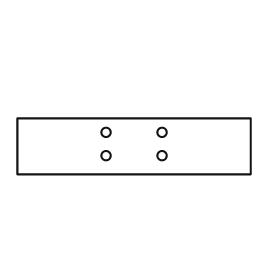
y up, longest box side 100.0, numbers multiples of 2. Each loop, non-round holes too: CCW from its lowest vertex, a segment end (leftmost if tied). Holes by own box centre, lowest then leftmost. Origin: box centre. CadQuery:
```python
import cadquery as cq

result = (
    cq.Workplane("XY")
    .moveTo(-50.0, -12.0)
    .lineTo(50.0, -12.0)
    .lineTo(50.0, 12.0)
    .lineTo(-50.0, 12.0)
    .close()
    .moveTo(-12.0, -4.0)
    .circle(2.0)
    .moveTo(12.0, -4.0)
    .circle(2.0)
    .moveTo(-12.0, 6.0)
    .circle(2.0)
    .moveTo(12.0, 6.0)
    .circle(2.0)
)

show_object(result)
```